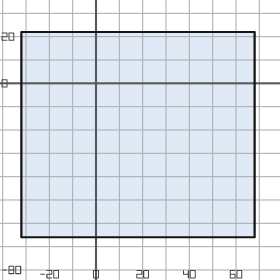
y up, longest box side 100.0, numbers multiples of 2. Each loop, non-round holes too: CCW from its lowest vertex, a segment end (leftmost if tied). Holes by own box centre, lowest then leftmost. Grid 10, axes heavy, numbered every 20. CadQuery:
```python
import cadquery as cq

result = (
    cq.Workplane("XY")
    .moveTo(-32.0, -66.0)
    .lineTo(68.0, -66.0)
    .lineTo(68.0, 22.0)
    .lineTo(-32.0, 22.0)
    .close()
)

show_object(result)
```